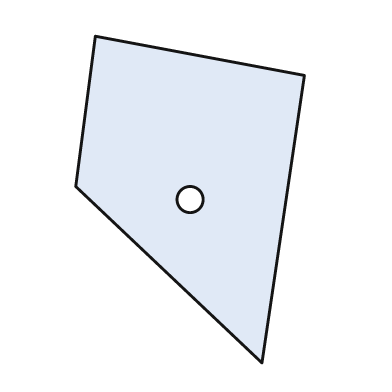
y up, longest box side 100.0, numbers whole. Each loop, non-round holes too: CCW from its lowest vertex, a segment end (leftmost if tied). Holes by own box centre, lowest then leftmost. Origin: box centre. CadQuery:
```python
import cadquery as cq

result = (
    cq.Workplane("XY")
    .moveTo(22.0, -50.0)
    .lineTo(35.0, 38.0)
    .lineTo(-29.0, 50.0)
    .lineTo(-35.0, 4.0)
    .close()
    .moveTo(0.0, 0.0)
    .circle(4.0)
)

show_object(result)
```